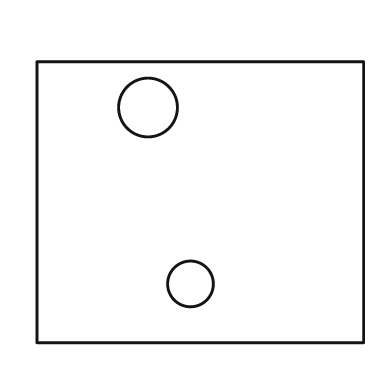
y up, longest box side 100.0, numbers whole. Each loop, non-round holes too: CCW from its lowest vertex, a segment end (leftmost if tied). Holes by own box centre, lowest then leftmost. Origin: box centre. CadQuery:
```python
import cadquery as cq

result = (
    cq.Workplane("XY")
    .moveTo(-50.0, -43.0)
    .lineTo(50.0, -43.0)
    .lineTo(50.0, 43.0)
    .lineTo(-50.0, 43.0)
    .close()
    .moveTo(-3.0, -25.0)
    .circle(7.0)
    .moveTo(-16.0, 29.0)
    .circle(9.0)
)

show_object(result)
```